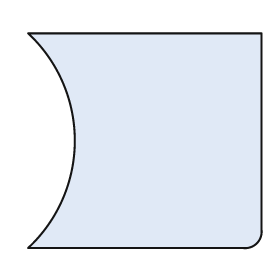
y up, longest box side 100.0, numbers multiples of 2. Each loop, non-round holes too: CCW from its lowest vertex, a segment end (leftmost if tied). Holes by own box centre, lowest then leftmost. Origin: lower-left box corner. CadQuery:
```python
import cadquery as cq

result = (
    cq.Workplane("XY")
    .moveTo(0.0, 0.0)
    .lineTo(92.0, 0.0)
    .threePointArc((98.0, 2.0), (100.0, 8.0))
    .lineTo(100.0, 92.0)
    .lineTo(0.0, 92.0)
    .threePointArc((20.0, 46.0), (0.0, 0.0))
    .close()
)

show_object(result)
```